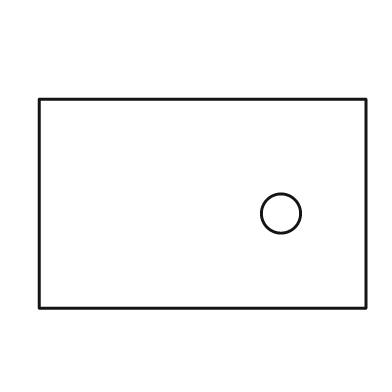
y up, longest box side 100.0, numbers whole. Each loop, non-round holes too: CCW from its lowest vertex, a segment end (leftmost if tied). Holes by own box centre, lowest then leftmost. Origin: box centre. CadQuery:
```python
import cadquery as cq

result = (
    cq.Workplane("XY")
    .moveTo(-50.0, -32.0)
    .lineTo(50.0, -32.0)
    .lineTo(50.0, 32.0)
    .lineTo(-50.0, 32.0)
    .close()
    .moveTo(24.0, -3.0)
    .circle(6.0)
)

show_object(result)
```